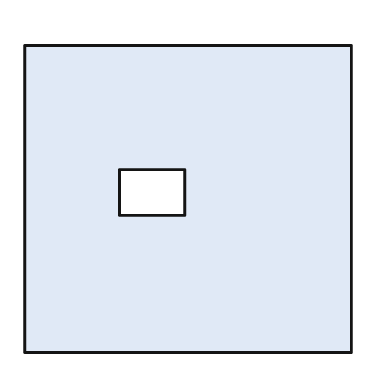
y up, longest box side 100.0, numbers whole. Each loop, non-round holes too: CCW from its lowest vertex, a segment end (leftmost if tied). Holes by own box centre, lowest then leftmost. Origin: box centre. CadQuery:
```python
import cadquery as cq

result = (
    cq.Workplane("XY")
    .moveTo(-50.0, -47.0)
    .lineTo(50.0, -47.0)
    .lineTo(50.0, 47.0)
    .lineTo(-50.0, 47.0)
    .close()
    .moveTo(-21.0, -5.0)
    .lineTo(-1.0, -5.0)
    .lineTo(-1.0, 9.0)
    .lineTo(-21.0, 9.0)
    .close()
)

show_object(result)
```